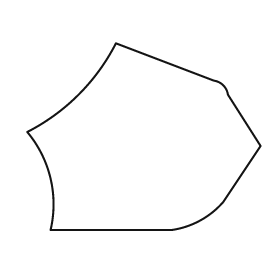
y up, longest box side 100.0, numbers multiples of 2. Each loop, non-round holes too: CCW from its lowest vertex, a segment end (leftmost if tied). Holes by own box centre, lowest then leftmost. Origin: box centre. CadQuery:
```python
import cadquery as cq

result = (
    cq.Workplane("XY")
    .moveTo(-40.0, -40.0)
    .lineTo(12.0, -40.0)
    .threePointArc((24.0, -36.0), (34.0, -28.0))
    .lineTo(50.0, -4.0)
    .lineTo(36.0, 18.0)
    .threePointArc((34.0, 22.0), (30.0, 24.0))
    .lineTo(-12.0, 40.0)
    .threePointArc((-28.0, 18.0), (-50.0, 2.0))
    .threePointArc((-40.0, -18.0), (-40.0, -40.0))
    .close()
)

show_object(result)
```